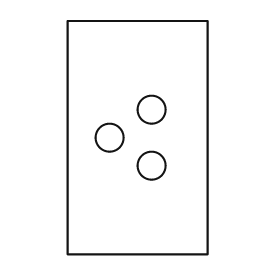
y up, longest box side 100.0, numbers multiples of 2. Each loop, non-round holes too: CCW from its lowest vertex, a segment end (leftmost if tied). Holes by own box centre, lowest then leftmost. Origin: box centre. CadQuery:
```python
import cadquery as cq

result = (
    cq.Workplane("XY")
    .moveTo(-30.0, -50.0)
    .lineTo(30.0, -50.0)
    .lineTo(30.0, 50.0)
    .lineTo(-30.0, 50.0)
    .close()
    .moveTo(6.0, -12.0)
    .circle(6.0)
    .moveTo(-12.0, 0.0)
    .circle(6.0)
    .moveTo(6.0, 12.0)
    .circle(6.0)
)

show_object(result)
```